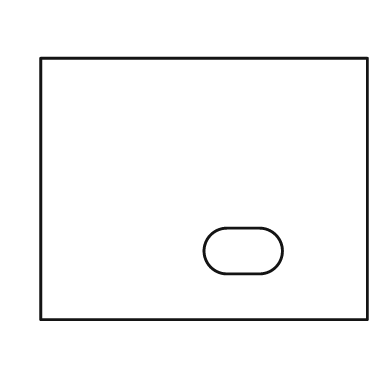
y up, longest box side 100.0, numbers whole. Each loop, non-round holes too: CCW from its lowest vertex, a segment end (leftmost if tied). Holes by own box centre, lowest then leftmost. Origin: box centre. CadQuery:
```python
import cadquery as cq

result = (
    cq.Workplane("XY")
    .moveTo(-50.0, -40.0)
    .lineTo(50.0, -40.0)
    .lineTo(50.0, 40.0)
    .lineTo(-50.0, 40.0)
    .close()
    .moveTo(7.0, -26.0)
    .lineTo(17.0, -26.0)
    .threePointArc((24.0, -19.0), (17.0, -12.0))
    .lineTo(7.0, -12.0)
    .threePointArc((0.0, -19.0), (7.0, -26.0))
    .close()
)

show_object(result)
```